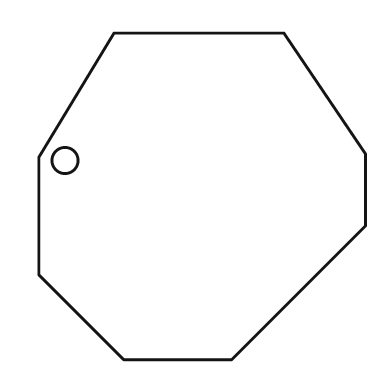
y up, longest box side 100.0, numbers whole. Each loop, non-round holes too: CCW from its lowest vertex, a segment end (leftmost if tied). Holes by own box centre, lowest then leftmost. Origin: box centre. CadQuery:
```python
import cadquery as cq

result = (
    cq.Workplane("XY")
    .moveTo(-24.0, -50.0)
    .lineTo(9.0, -50.0)
    .lineTo(50.0, -9.0)
    .lineTo(50.0, 13.0)
    .lineTo(25.0, 50.0)
    .lineTo(-27.0, 50.0)
    .lineTo(-50.0, 12.0)
    .lineTo(-50.0, -24.0)
    .close()
    .moveTo(-42.0, 11.0)
    .circle(4.0)
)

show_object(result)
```